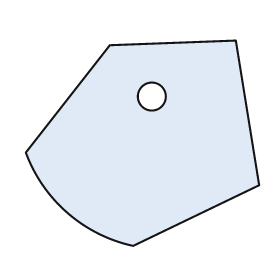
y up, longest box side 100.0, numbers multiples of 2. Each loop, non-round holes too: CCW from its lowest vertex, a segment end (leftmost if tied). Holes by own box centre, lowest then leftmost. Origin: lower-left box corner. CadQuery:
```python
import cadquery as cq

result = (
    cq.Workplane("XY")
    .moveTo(46.0, 0.0)
    .lineTo(100.0, 26.0)
    .lineTo(90.0, 88.0)
    .lineTo(36.0, 86.0)
    .lineTo(0.0, 40.0)
    .threePointArc((18.0, 14.0), (46.0, 0.0))
    .close()
    .moveTo(54.0, 64.0)
    .circle(6.0)
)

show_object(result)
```